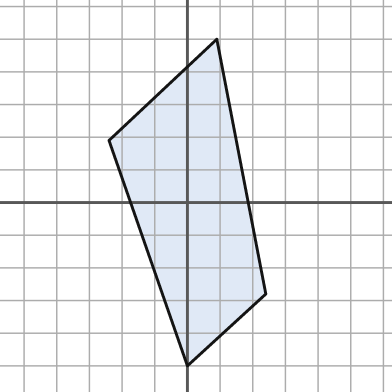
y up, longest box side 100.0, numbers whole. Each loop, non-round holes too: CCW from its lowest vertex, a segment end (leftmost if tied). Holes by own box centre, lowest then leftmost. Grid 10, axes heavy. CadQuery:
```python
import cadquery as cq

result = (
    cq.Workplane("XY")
    .moveTo(0.0, -50.0)
    .lineTo(24.0, -28.0)
    .lineTo(9.0, 50.0)
    .lineTo(-24.0, 19.0)
    .close()
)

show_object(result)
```